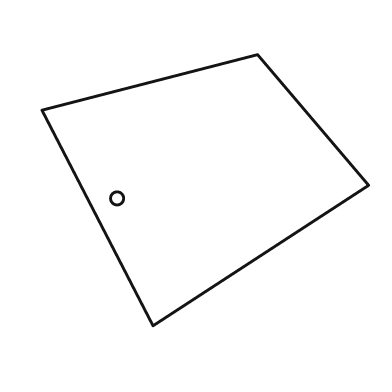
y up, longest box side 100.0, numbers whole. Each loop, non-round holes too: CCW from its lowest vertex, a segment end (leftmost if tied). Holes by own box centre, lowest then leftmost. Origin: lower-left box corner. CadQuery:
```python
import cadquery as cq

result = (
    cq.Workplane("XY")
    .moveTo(34.0, 0.0)
    .lineTo(100.0, 43.0)
    .lineTo(66.0, 83.0)
    .lineTo(0.0, 66.0)
    .close()
    .moveTo(23.0, 39.0)
    .circle(2.0)
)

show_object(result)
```